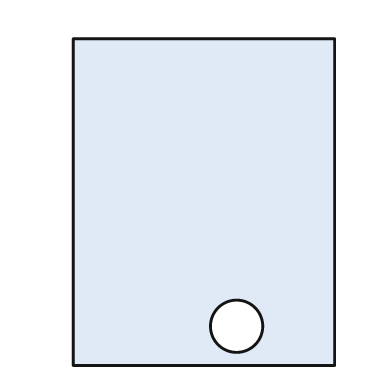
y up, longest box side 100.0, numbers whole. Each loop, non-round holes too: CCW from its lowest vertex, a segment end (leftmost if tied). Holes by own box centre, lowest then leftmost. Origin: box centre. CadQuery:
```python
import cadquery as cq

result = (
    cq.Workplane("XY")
    .moveTo(-40.0, -50.0)
    .lineTo(40.0, -50.0)
    .lineTo(40.0, 50.0)
    .lineTo(-40.0, 50.0)
    .close()
    .moveTo(10.0, -38.0)
    .circle(8.0)
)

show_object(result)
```